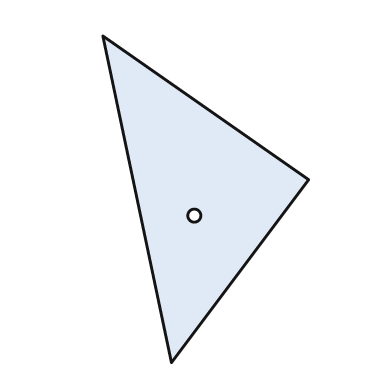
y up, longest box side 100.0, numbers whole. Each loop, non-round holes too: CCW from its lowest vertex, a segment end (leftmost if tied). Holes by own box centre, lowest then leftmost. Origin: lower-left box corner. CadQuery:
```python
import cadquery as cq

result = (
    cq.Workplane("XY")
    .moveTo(21.0, 0.0)
    .lineTo(63.0, 56.0)
    .lineTo(0.0, 100.0)
    .close()
    .moveTo(28.0, 45.0)
    .circle(2.0)
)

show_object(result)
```